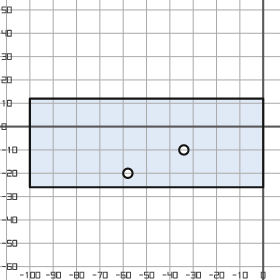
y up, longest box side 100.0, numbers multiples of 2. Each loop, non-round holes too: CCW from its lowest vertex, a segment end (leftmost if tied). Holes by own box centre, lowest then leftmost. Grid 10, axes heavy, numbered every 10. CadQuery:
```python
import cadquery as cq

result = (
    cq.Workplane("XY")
    .moveTo(-100.0, -26.0)
    .lineTo(0.0, -26.0)
    .lineTo(0.0, 12.0)
    .lineTo(-100.0, 12.0)
    .close()
    .moveTo(-58.0, -20.0)
    .circle(2.0)
    .moveTo(-34.0, -10.0)
    .circle(2.0)
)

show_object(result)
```